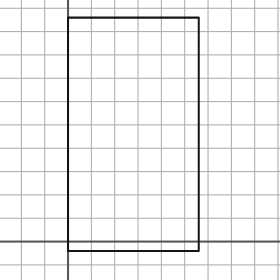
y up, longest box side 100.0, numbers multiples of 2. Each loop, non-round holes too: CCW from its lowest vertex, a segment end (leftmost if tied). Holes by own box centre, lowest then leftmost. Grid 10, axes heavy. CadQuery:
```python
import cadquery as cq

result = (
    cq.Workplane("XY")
    .moveTo(0.0, -4.0)
    .lineTo(56.0, -4.0)
    .lineTo(56.0, 96.0)
    .lineTo(0.0, 96.0)
    .close()
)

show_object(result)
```